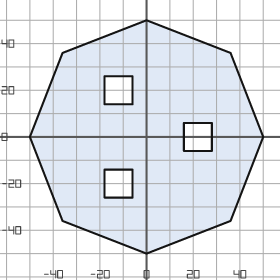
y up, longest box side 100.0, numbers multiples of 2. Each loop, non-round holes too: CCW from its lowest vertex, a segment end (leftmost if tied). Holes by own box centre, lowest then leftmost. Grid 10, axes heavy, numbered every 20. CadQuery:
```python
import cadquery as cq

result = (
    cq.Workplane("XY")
    .moveTo(0.0, -50.0)
    .lineTo(36.0, -36.0)
    .lineTo(50.0, 0.0)
    .lineTo(36.0, 36.0)
    .lineTo(0.0, 50.0)
    .lineTo(-36.0, 36.0)
    .lineTo(-50.0, 0.0)
    .lineTo(-36.0, -36.0)
    .close()
    .moveTo(-18.0, -26.0)
    .lineTo(-6.0, -26.0)
    .lineTo(-6.0, -14.0)
    .lineTo(-18.0, -14.0)
    .close()
    .moveTo(16.0, -6.0)
    .lineTo(28.0, -6.0)
    .lineTo(28.0, 6.0)
    .lineTo(16.0, 6.0)
    .close()
    .moveTo(-18.0, 14.0)
    .lineTo(-6.0, 14.0)
    .lineTo(-6.0, 26.0)
    .lineTo(-18.0, 26.0)
    .close()
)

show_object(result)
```